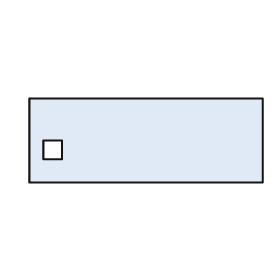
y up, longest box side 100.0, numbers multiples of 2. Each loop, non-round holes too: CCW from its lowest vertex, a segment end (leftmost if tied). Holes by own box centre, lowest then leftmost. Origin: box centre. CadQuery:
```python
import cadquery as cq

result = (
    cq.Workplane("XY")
    .moveTo(-50.0, -18.0)
    .lineTo(50.0, -18.0)
    .lineTo(50.0, 18.0)
    .lineTo(-50.0, 18.0)
    .close()
    .moveTo(-44.0, -8.0)
    .lineTo(-36.0, -8.0)
    .lineTo(-36.0, 0.0)
    .lineTo(-44.0, 0.0)
    .close()
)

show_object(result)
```